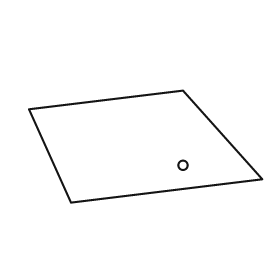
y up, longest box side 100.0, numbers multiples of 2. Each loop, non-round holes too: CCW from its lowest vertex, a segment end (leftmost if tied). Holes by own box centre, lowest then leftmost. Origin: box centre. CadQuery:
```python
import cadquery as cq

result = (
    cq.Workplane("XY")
    .moveTo(-32.0, -24.0)
    .lineTo(50.0, -14.0)
    .lineTo(16.0, 24.0)
    .lineTo(-50.0, 16.0)
    .close()
    .moveTo(16.0, -8.0)
    .circle(2.0)
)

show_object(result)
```